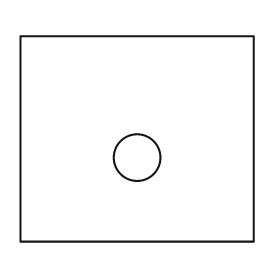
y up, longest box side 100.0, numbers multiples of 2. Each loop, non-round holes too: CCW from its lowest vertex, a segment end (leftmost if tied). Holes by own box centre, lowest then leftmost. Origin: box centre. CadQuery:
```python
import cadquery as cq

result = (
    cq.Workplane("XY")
    .moveTo(-50.0, -44.0)
    .lineTo(50.0, -44.0)
    .lineTo(50.0, 44.0)
    .lineTo(-50.0, 44.0)
    .close()
    .moveTo(0.0, -8.0)
    .circle(10.0)
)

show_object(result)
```